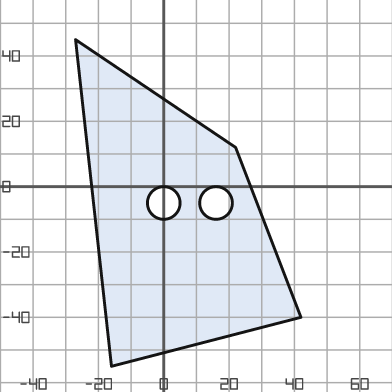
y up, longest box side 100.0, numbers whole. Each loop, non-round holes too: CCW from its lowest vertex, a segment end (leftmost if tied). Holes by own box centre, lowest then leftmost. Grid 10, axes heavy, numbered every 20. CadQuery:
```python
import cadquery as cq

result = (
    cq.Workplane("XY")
    .moveTo(-16.0, -55.0)
    .lineTo(42.0, -40.0)
    .lineTo(22.0, 12.0)
    .lineTo(-27.0, 45.0)
    .close()
    .moveTo(0.0, -5.0)
    .circle(5.0)
    .moveTo(16.0, -5.0)
    .circle(5.0)
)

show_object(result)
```